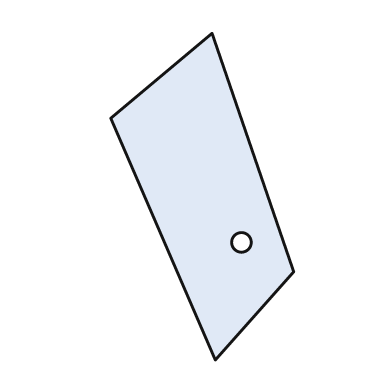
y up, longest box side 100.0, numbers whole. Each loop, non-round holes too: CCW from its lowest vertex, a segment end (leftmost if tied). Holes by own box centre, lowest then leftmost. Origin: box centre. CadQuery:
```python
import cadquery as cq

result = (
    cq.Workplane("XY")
    .moveTo(4.0, -50.0)
    .lineTo(28.0, -23.0)
    .lineTo(3.0, 50.0)
    .lineTo(-28.0, 24.0)
    .close()
    .moveTo(12.0, -14.0)
    .circle(3.0)
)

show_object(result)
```